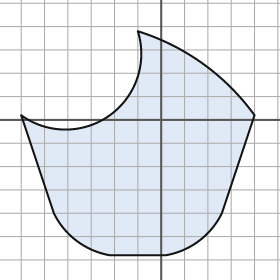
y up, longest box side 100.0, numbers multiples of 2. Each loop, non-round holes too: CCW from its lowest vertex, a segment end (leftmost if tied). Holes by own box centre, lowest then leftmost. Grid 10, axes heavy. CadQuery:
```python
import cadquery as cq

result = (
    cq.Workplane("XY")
    .moveTo(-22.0, -58.0)
    .lineTo(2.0, -58.0)
    .threePointArc((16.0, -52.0), (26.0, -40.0))
    .lineTo(40.0, 2.0)
    .threePointArc((18.0, 24.0), (-10.0, 38.0))
    .threePointArc((-22.0, 2.0), (-60.0, 2.0))
    .lineTo(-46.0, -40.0)
    .threePointArc((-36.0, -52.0), (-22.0, -58.0))
    .close()
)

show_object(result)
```